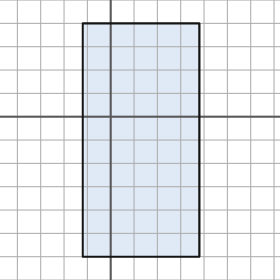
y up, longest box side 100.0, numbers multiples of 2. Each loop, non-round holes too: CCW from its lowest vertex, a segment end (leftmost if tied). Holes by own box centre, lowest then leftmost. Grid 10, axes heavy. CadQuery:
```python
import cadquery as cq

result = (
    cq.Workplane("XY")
    .moveTo(-12.0, -60.0)
    .lineTo(38.0, -60.0)
    .lineTo(38.0, 40.0)
    .lineTo(-12.0, 40.0)
    .close()
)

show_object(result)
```